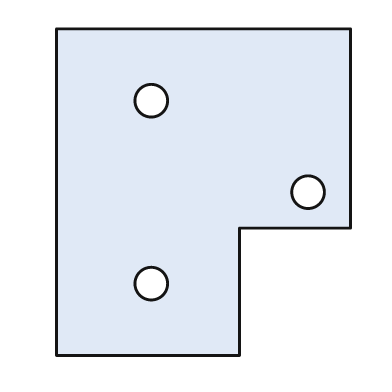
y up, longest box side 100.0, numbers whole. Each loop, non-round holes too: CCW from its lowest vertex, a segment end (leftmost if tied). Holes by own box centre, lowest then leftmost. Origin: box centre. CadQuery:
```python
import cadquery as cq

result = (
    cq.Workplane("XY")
    .moveTo(-45.0, -50.0)
    .lineTo(11.0, -50.0)
    .lineTo(11.0, -11.0)
    .lineTo(45.0, -11.0)
    .lineTo(45.0, 50.0)
    .lineTo(-45.0, 50.0)
    .close()
    .moveTo(-16.0, -28.0)
    .circle(5.0)
    .moveTo(32.0, 0.0)
    .circle(5.0)
    .moveTo(-16.0, 28.0)
    .circle(5.0)
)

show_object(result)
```